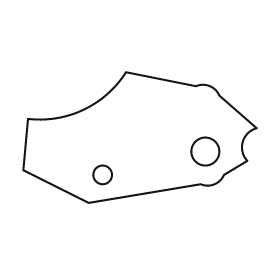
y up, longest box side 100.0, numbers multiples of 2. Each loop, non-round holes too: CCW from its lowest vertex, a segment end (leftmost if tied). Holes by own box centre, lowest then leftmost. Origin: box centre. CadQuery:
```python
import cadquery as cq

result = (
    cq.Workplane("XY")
    .moveTo(-22.0, -28.0)
    .lineTo(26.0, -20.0)
    .threePointArc((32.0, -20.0), (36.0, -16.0))
    .lineTo(46.0, -10.0)
    .threePointArc((44.0, -2.0), (50.0, 4.0))
    .lineTo(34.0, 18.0)
    .threePointArc((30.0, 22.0), (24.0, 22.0))
    .lineTo(-6.0, 28.0)
    .threePointArc((-24.0, 12.0), (-48.0, 8.0))
    .lineTo(-50.0, -14.0)
    .close()
    .moveTo(-16.0, -16.0)
    .circle(4.0)
    .moveTo(28.0, -6.0)
    .circle(6.0)
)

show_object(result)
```